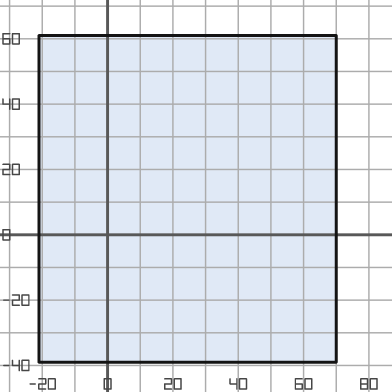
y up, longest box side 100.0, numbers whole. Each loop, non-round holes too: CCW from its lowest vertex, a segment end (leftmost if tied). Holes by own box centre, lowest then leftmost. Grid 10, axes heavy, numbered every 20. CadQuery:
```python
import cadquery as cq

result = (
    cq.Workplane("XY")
    .moveTo(-21.0, -39.0)
    .lineTo(70.0, -39.0)
    .lineTo(70.0, 61.0)
    .lineTo(-21.0, 61.0)
    .close()
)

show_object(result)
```